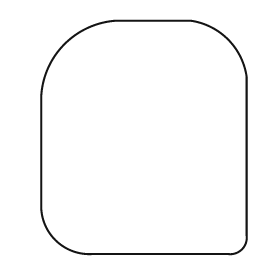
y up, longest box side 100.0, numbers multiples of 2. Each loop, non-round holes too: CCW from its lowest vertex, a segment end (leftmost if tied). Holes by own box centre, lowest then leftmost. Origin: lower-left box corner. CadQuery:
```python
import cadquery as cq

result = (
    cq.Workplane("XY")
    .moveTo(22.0, 0.0)
    .lineTo(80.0, 0.0)
    .threePointArc((86.0, 2.0), (88.0, 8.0))
    .lineTo(88.0, 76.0)
    .threePointArc((80.0, 92.0), (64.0, 100.0))
    .lineTo(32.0, 100.0)
    .threePointArc((10.0, 90.0), (0.0, 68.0))
    .lineTo(0.0, 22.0)
    .threePointArc((6.0, 6.0), (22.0, 0.0))
    .close()
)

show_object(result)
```